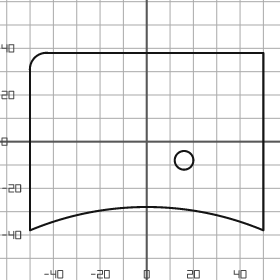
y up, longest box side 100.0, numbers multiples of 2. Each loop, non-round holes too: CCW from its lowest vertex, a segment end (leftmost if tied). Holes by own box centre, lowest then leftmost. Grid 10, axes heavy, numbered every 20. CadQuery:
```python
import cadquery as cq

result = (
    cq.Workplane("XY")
    .moveTo(-50.0, -38.0)
    .threePointArc((0.0, -28.0), (50.0, -38.0))
    .lineTo(50.0, 38.0)
    .lineTo(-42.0, 38.0)
    .threePointArc((-48.0, 36.0), (-50.0, 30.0))
    .close()
    .moveTo(16.0, -8.0)
    .circle(4.0)
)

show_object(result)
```